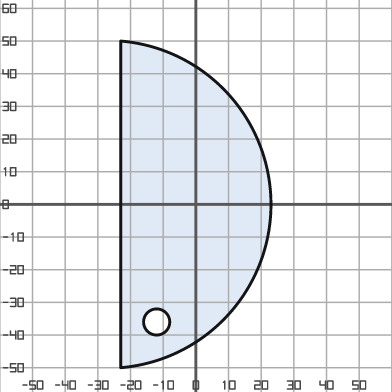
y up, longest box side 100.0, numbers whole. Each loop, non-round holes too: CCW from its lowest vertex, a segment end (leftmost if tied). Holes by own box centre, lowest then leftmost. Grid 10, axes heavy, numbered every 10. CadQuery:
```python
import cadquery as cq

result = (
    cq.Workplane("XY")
    .moveTo(-23.0, -50.0)
    .threePointArc((23.0, 0.0), (-23.0, 50.0))
    .close()
    .moveTo(-12.0, -36.0)
    .circle(4.0)
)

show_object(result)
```